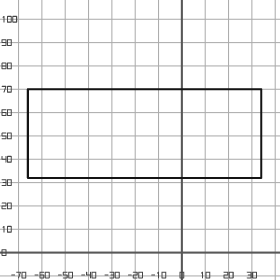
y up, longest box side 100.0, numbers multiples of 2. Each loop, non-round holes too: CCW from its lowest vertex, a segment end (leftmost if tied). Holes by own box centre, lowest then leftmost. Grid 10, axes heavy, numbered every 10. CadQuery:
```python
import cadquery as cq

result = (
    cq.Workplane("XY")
    .moveTo(-66.0, 32.0)
    .lineTo(34.0, 32.0)
    .lineTo(34.0, 70.0)
    .lineTo(-66.0, 70.0)
    .close()
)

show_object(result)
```